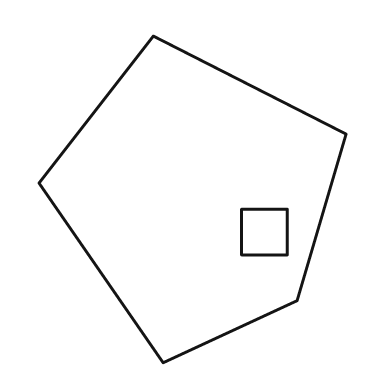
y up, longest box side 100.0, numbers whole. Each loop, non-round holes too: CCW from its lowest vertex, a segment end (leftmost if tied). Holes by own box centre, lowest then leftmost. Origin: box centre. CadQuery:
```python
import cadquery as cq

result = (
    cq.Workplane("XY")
    .moveTo(-9.0, -50.0)
    .lineTo(32.0, -31.0)
    .lineTo(47.0, 20.0)
    .lineTo(-12.0, 50.0)
    .lineTo(-47.0, 5.0)
    .close()
    .moveTo(15.0, -17.0)
    .lineTo(29.0, -17.0)
    .lineTo(29.0, -3.0)
    .lineTo(15.0, -3.0)
    .close()
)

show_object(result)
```